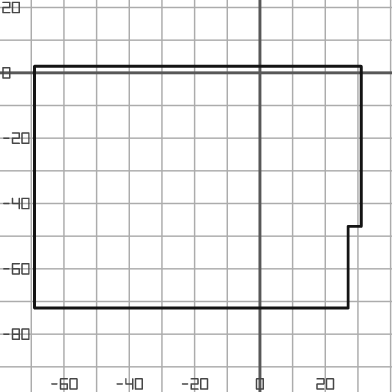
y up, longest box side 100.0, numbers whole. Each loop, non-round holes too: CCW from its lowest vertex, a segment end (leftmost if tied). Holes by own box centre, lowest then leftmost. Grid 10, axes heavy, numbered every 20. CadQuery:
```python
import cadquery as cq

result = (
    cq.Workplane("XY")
    .moveTo(-69.0, -72.0)
    .lineTo(27.0, -72.0)
    .lineTo(27.0, -47.0)
    .lineTo(31.0, -47.0)
    .lineTo(31.0, 2.0)
    .lineTo(-69.0, 2.0)
    .close()
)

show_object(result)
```